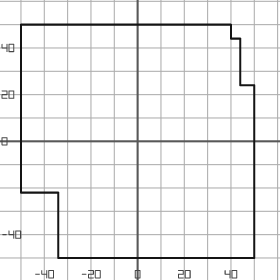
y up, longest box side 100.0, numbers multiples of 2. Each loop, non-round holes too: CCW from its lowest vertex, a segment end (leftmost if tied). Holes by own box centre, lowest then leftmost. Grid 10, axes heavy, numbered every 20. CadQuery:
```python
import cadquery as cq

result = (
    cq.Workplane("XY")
    .moveTo(-34.0, -50.0)
    .lineTo(50.0, -50.0)
    .lineTo(50.0, 24.0)
    .lineTo(44.0, 24.0)
    .lineTo(44.0, 44.0)
    .lineTo(40.0, 44.0)
    .lineTo(40.0, 50.0)
    .lineTo(-50.0, 50.0)
    .lineTo(-50.0, -22.0)
    .lineTo(-34.0, -22.0)
    .close()
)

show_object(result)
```